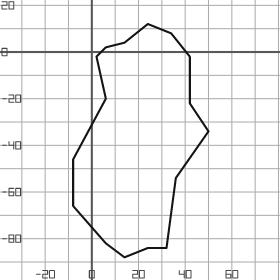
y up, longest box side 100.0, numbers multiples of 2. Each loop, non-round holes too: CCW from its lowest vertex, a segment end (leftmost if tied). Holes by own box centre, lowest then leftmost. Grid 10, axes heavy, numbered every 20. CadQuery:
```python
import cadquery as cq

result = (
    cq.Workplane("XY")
    .moveTo(14.0, -88.0)
    .lineTo(24.0, -84.0)
    .lineTo(32.0, -84.0)
    .lineTo(36.0, -54.0)
    .lineTo(50.0, -34.0)
    .lineTo(42.0, -22.0)
    .lineTo(42.0, -2.0)
    .lineTo(34.0, 8.0)
    .lineTo(24.0, 12.0)
    .lineTo(14.0, 4.0)
    .lineTo(6.0, 2.0)
    .lineTo(2.0, -2.0)
    .lineTo(6.0, -20.0)
    .lineTo(-8.0, -46.0)
    .lineTo(-8.0, -66.0)
    .lineTo(6.0, -82.0)
    .close()
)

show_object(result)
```